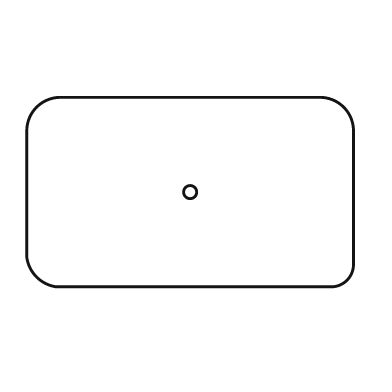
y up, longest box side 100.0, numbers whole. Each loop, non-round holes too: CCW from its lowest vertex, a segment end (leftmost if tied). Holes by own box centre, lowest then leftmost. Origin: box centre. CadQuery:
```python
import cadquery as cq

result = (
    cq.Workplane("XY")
    .moveTo(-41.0, -29.0)
    .lineTo(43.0, -29.0)
    .threePointArc((48.0, -27.0), (50.0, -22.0))
    .lineTo(50.0, 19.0)
    .threePointArc((47.0, 26.0), (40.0, 29.0))
    .lineTo(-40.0, 29.0)
    .threePointArc((-47.0, 26.0), (-50.0, 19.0))
    .lineTo(-50.0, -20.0)
    .threePointArc((-47.0, -26.0), (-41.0, -29.0))
    .close()
    .moveTo(0.0, 0.0)
    .circle(2.0)
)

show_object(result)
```